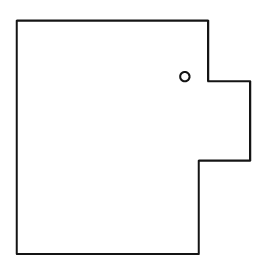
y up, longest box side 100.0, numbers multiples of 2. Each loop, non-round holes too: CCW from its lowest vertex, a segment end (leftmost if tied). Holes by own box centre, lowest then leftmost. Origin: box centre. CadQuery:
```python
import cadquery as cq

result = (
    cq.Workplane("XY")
    .moveTo(-50.0, -50.0)
    .lineTo(28.0, -50.0)
    .lineTo(28.0, -10.0)
    .lineTo(50.0, -10.0)
    .lineTo(50.0, 24.0)
    .lineTo(32.0, 24.0)
    .lineTo(32.0, 50.0)
    .lineTo(-50.0, 50.0)
    .close()
    .moveTo(22.0, 26.0)
    .circle(2.0)
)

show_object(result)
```